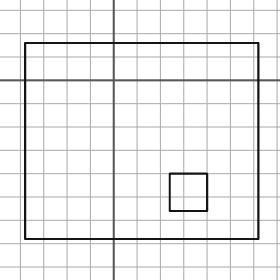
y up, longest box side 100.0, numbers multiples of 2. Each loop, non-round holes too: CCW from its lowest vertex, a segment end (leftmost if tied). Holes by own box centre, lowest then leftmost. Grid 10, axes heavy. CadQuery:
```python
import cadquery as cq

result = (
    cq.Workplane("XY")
    .moveTo(-38.0, -68.0)
    .lineTo(62.0, -68.0)
    .lineTo(62.0, 16.0)
    .lineTo(-38.0, 16.0)
    .close()
    .moveTo(24.0, -56.0)
    .lineTo(40.0, -56.0)
    .lineTo(40.0, -40.0)
    .lineTo(24.0, -40.0)
    .close()
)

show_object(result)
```